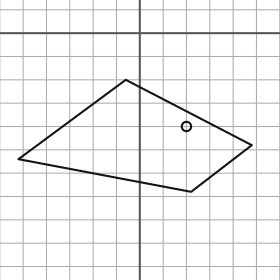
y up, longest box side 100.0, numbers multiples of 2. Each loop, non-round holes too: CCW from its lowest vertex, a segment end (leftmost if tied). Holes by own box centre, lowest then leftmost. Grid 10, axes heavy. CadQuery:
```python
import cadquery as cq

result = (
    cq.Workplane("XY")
    .moveTo(22.0, -68.0)
    .lineTo(48.0, -48.0)
    .lineTo(-6.0, -20.0)
    .lineTo(-52.0, -54.0)
    .close()
    .moveTo(20.0, -40.0)
    .circle(2.0)
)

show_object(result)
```